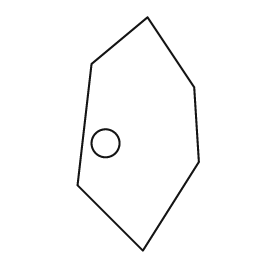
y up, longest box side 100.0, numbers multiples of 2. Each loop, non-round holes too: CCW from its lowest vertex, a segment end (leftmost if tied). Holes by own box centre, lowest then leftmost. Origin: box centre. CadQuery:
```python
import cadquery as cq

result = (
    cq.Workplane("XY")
    .moveTo(2.0, -50.0)
    .lineTo(26.0, -12.0)
    .lineTo(24.0, 20.0)
    .lineTo(4.0, 50.0)
    .lineTo(-20.0, 30.0)
    .lineTo(-26.0, -22.0)
    .close()
    .moveTo(-14.0, -4.0)
    .circle(6.0)
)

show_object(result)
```